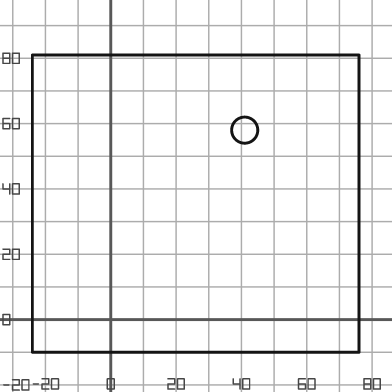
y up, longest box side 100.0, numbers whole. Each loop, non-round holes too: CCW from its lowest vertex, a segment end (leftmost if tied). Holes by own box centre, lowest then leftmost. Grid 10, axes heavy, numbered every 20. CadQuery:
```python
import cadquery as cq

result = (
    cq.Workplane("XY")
    .moveTo(-24.0, -10.0)
    .lineTo(76.0, -10.0)
    .lineTo(76.0, 81.0)
    .lineTo(-24.0, 81.0)
    .close()
    .moveTo(41.0, 58.0)
    .circle(4.0)
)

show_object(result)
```